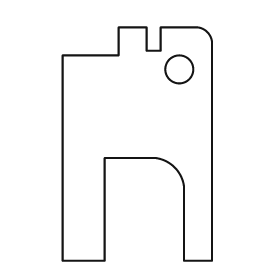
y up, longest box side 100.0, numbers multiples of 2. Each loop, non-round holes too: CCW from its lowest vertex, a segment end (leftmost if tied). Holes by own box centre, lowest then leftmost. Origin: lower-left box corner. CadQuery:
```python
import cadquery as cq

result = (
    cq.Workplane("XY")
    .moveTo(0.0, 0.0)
    .lineTo(18.0, 0.0)
    .lineTo(18.0, 44.0)
    .lineTo(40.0, 44.0)
    .threePointArc((48.0, 40.0), (52.0, 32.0))
    .lineTo(52.0, 0.0)
    .lineTo(64.0, 0.0)
    .lineTo(64.0, 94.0)
    .threePointArc((62.0, 98.0), (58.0, 100.0))
    .lineTo(42.0, 100.0)
    .lineTo(42.0, 90.0)
    .lineTo(36.0, 90.0)
    .lineTo(36.0, 100.0)
    .lineTo(24.0, 100.0)
    .lineTo(24.0, 88.0)
    .lineTo(0.0, 88.0)
    .close()
    .moveTo(50.0, 82.0)
    .circle(6.0)
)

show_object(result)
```